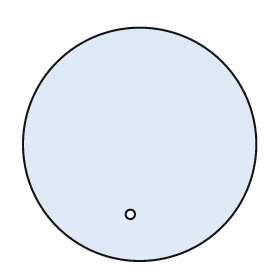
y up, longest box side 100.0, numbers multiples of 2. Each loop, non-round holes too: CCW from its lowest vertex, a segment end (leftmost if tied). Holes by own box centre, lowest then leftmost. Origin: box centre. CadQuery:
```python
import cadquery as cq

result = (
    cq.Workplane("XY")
    .moveTo(0.0, 0.0)
    .circle(50.0)
    .moveTo(-4.0, -30.0)
    .circle(2.0)
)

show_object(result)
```